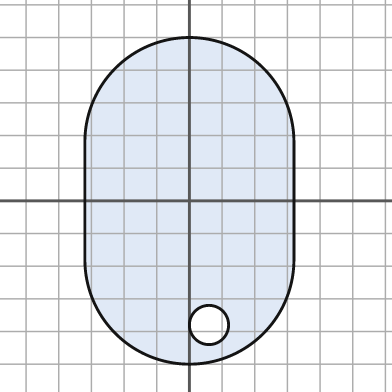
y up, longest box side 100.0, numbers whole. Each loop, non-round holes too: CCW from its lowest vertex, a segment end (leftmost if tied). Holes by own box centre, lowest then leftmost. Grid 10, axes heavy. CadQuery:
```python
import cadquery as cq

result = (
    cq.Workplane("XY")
    .moveTo(-32.0, -18.0)
    .threePointArc((0.0, -50.0), (32.0, -18.0))
    .lineTo(32.0, 18.0)
    .threePointArc((0.0, 50.0), (-32.0, 18.0))
    .close()
    .moveTo(6.0, -38.0)
    .circle(6.0)
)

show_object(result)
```